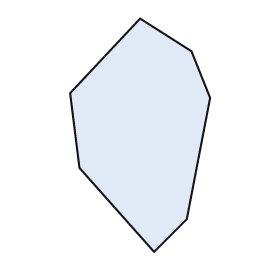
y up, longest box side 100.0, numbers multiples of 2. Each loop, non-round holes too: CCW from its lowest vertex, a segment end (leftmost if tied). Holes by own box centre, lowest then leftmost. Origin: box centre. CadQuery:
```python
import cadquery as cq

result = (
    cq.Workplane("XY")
    .moveTo(6.0, -50.0)
    .lineTo(20.0, -36.0)
    .lineTo(30.0, 16.0)
    .lineTo(22.0, 36.0)
    .lineTo(0.0, 50.0)
    .lineTo(-30.0, 18.0)
    .lineTo(-26.0, -14.0)
    .close()
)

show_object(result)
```